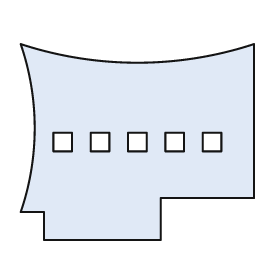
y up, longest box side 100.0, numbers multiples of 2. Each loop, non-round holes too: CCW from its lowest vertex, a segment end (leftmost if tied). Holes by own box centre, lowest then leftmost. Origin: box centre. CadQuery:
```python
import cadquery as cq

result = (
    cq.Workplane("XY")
    .moveTo(-40.0, -42.0)
    .lineTo(10.0, -42.0)
    .lineTo(10.0, -24.0)
    .lineTo(50.0, -24.0)
    .lineTo(50.0, 42.0)
    .threePointArc((0.0, 34.0), (-50.0, 42.0))
    .threePointArc((-44.0, 6.0), (-50.0, -30.0))
    .lineTo(-40.0, -30.0)
    .close()
    .moveTo(-36.0, -4.0)
    .lineTo(-28.0, -4.0)
    .lineTo(-28.0, 4.0)
    .lineTo(-36.0, 4.0)
    .close()
    .moveTo(-20.0, -4.0)
    .lineTo(-12.0, -4.0)
    .lineTo(-12.0, 4.0)
    .lineTo(-20.0, 4.0)
    .close()
    .moveTo(-4.0, -4.0)
    .lineTo(4.0, -4.0)
    .lineTo(4.0, 4.0)
    .lineTo(-4.0, 4.0)
    .close()
    .moveTo(12.0, -4.0)
    .lineTo(20.0, -4.0)
    .lineTo(20.0, 4.0)
    .lineTo(12.0, 4.0)
    .close()
    .moveTo(28.0, -4.0)
    .lineTo(36.0, -4.0)
    .lineTo(36.0, 4.0)
    .lineTo(28.0, 4.0)
    .close()
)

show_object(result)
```